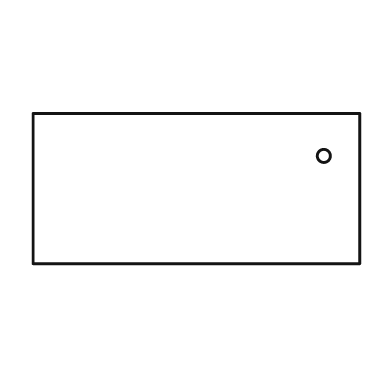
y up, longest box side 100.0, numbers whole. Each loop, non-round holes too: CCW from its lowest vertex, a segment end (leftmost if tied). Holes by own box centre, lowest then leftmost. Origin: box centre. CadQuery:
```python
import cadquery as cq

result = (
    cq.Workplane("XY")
    .moveTo(-50.0, -23.0)
    .lineTo(50.0, -23.0)
    .lineTo(50.0, 23.0)
    .lineTo(-50.0, 23.0)
    .close()
    .moveTo(39.0, 10.0)
    .circle(2.0)
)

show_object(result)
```